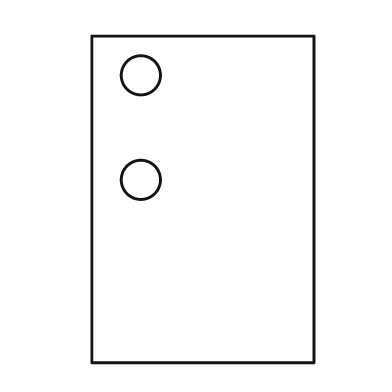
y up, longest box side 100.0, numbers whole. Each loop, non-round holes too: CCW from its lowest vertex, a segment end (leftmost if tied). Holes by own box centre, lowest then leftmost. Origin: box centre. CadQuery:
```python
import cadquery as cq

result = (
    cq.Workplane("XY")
    .moveTo(-34.0, -50.0)
    .lineTo(34.0, -50.0)
    .lineTo(34.0, 50.0)
    .lineTo(-34.0, 50.0)
    .close()
    .moveTo(-19.0, 6.0)
    .circle(6.0)
    .moveTo(-19.0, 38.0)
    .circle(6.0)
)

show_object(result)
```